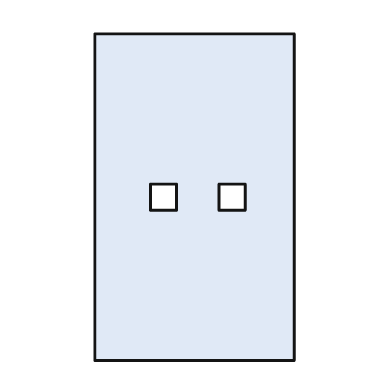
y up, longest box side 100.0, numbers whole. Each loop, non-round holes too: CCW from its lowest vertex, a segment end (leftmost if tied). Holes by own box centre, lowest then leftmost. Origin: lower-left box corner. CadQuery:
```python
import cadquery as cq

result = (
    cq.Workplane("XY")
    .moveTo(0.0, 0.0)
    .lineTo(61.0, 0.0)
    .lineTo(61.0, 100.0)
    .lineTo(0.0, 100.0)
    .close()
    .moveTo(17.0, 46.0)
    .lineTo(25.0, 46.0)
    .lineTo(25.0, 54.0)
    .lineTo(17.0, 54.0)
    .close()
    .moveTo(38.0, 46.0)
    .lineTo(46.0, 46.0)
    .lineTo(46.0, 54.0)
    .lineTo(38.0, 54.0)
    .close()
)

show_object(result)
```